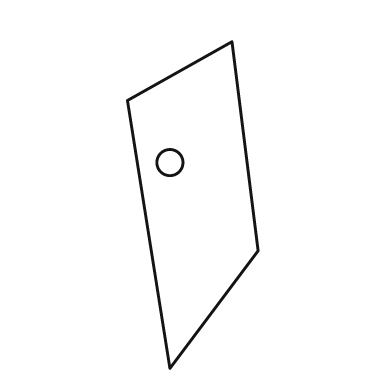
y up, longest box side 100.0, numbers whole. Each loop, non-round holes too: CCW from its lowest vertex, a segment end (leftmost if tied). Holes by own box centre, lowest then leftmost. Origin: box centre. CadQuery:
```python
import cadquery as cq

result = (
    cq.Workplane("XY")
    .moveTo(-7.0, -50.0)
    .lineTo(20.0, -14.0)
    .lineTo(12.0, 50.0)
    .lineTo(-20.0, 32.0)
    .close()
    .moveTo(-7.0, 13.0)
    .circle(4.0)
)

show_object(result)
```